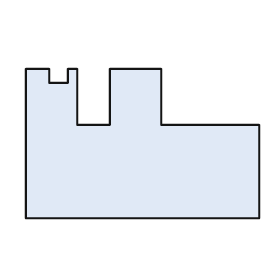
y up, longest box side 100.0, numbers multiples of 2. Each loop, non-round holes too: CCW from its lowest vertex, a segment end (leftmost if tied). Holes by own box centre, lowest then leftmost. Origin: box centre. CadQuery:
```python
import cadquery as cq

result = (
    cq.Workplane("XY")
    .moveTo(-50.0, -32.0)
    .lineTo(50.0, -32.0)
    .lineTo(50.0, 8.0)
    .lineTo(8.0, 8.0)
    .lineTo(8.0, 32.0)
    .lineTo(-14.0, 32.0)
    .lineTo(-14.0, 8.0)
    .lineTo(-28.0, 8.0)
    .lineTo(-28.0, 32.0)
    .lineTo(-32.0, 32.0)
    .lineTo(-32.0, 26.0)
    .lineTo(-40.0, 26.0)
    .lineTo(-40.0, 32.0)
    .lineTo(-50.0, 32.0)
    .close()
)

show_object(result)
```